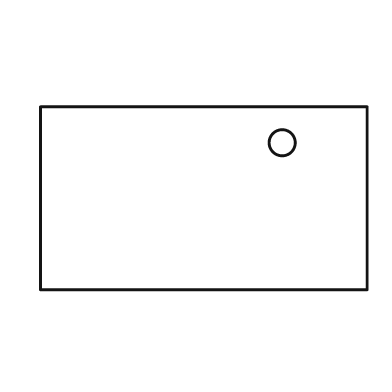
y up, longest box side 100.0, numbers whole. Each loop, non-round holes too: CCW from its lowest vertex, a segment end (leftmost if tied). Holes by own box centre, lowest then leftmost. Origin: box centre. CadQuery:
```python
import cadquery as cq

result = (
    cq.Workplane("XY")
    .moveTo(-50.0, -28.0)
    .lineTo(50.0, -28.0)
    .lineTo(50.0, 28.0)
    .lineTo(-50.0, 28.0)
    .close()
    .moveTo(24.0, 17.0)
    .circle(4.0)
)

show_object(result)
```